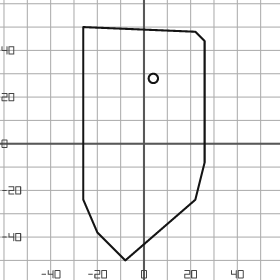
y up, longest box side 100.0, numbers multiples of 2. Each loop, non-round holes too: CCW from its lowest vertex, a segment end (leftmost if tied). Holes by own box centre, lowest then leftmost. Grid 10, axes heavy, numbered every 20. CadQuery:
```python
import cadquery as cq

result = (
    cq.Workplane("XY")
    .moveTo(-8.0, -50.0)
    .lineTo(22.0, -24.0)
    .lineTo(26.0, -8.0)
    .lineTo(26.0, 44.0)
    .lineTo(22.0, 48.0)
    .lineTo(-26.0, 50.0)
    .lineTo(-26.0, -24.0)
    .lineTo(-20.0, -38.0)
    .close()
    .moveTo(4.0, 28.0)
    .circle(2.0)
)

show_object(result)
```